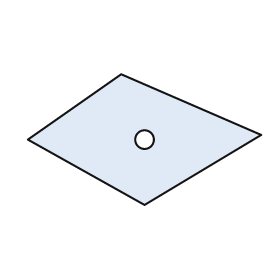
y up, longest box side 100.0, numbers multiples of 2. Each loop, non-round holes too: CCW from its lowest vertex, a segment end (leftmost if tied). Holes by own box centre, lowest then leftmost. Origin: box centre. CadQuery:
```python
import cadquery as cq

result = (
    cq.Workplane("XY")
    .moveTo(0.0, -28.0)
    .lineTo(50.0, 2.0)
    .lineTo(-10.0, 28.0)
    .lineTo(-50.0, 0.0)
    .close()
    .moveTo(0.0, 0.0)
    .circle(4.0)
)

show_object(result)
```